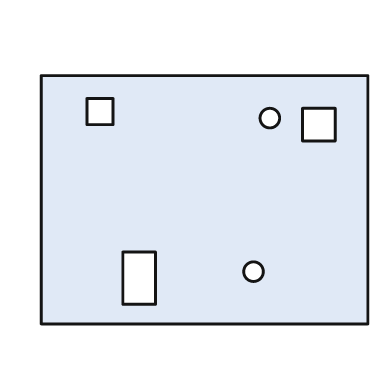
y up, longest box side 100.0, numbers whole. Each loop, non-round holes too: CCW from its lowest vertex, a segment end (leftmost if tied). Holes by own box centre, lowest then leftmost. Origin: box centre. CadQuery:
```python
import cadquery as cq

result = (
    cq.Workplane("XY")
    .moveTo(-50.0, -38.0)
    .lineTo(50.0, -38.0)
    .lineTo(50.0, 38.0)
    .lineTo(-50.0, 38.0)
    .close()
    .moveTo(-25.0, -32.0)
    .lineTo(-15.0, -32.0)
    .lineTo(-15.0, -16.0)
    .lineTo(-25.0, -16.0)
    .close()
    .moveTo(15.0, -22.0)
    .circle(3.0)
    .moveTo(30.0, 18.0)
    .lineTo(40.0, 18.0)
    .lineTo(40.0, 28.0)
    .lineTo(30.0, 28.0)
    .close()
    .moveTo(20.0, 25.0)
    .circle(3.0)
    .moveTo(-36.0, 23.0)
    .lineTo(-28.0, 23.0)
    .lineTo(-28.0, 31.0)
    .lineTo(-36.0, 31.0)
    .close()
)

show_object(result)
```